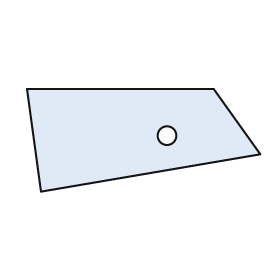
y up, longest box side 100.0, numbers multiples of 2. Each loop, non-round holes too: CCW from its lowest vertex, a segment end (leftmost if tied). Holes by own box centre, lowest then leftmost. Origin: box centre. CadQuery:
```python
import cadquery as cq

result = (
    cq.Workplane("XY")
    .moveTo(-44.0, -22.0)
    .lineTo(50.0, -6.0)
    .lineTo(30.0, 22.0)
    .lineTo(-50.0, 22.0)
    .close()
    .moveTo(10.0, 2.0)
    .circle(4.0)
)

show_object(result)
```